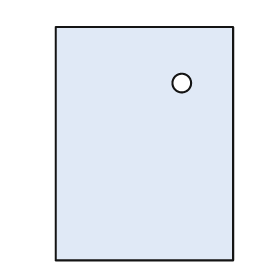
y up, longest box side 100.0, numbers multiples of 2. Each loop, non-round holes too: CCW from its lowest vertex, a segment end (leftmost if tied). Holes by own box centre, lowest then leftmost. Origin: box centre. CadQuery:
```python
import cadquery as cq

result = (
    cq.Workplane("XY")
    .moveTo(-38.0, -50.0)
    .lineTo(38.0, -50.0)
    .lineTo(38.0, 50.0)
    .lineTo(-38.0, 50.0)
    .close()
    .moveTo(16.0, 26.0)
    .circle(4.0)
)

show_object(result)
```